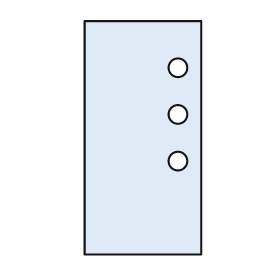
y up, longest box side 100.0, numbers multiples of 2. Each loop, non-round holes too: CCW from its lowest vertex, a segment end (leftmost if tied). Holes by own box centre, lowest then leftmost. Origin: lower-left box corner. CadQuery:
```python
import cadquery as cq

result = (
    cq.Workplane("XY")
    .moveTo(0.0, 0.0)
    .lineTo(50.0, 0.0)
    .lineTo(50.0, 100.0)
    .lineTo(0.0, 100.0)
    .close()
    .moveTo(40.0, 40.0)
    .circle(4.0)
    .moveTo(40.0, 60.0)
    .circle(4.0)
    .moveTo(40.0, 80.0)
    .circle(4.0)
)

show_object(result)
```